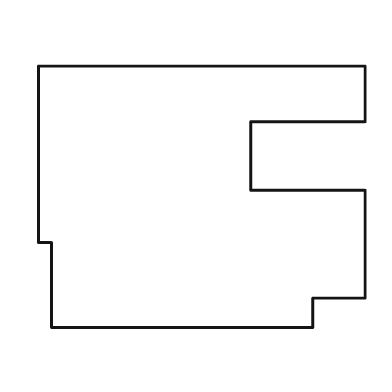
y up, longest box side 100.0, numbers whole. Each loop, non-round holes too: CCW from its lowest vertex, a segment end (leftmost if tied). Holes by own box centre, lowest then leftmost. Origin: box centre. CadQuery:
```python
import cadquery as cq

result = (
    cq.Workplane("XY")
    .moveTo(-46.0, -40.0)
    .lineTo(34.0, -40.0)
    .lineTo(34.0, -31.0)
    .lineTo(50.0, -31.0)
    .lineTo(50.0, 2.0)
    .lineTo(15.0, 2.0)
    .lineTo(15.0, 23.0)
    .lineTo(50.0, 23.0)
    .lineTo(50.0, 40.0)
    .lineTo(-50.0, 40.0)
    .lineTo(-50.0, -14.0)
    .lineTo(-46.0, -14.0)
    .close()
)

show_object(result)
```